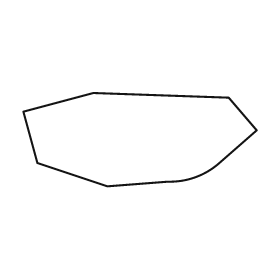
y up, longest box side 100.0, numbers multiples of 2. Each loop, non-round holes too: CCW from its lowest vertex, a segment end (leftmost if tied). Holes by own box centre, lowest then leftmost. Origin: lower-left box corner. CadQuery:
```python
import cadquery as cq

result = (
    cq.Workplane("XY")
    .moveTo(36.0, 0.0)
    .lineTo(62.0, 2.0)
    .threePointArc((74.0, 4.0), (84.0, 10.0))
    .lineTo(100.0, 24.0)
    .lineTo(88.0, 38.0)
    .lineTo(30.0, 40.0)
    .lineTo(0.0, 32.0)
    .lineTo(6.0, 10.0)
    .close()
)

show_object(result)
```